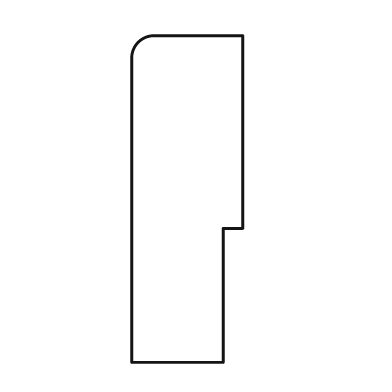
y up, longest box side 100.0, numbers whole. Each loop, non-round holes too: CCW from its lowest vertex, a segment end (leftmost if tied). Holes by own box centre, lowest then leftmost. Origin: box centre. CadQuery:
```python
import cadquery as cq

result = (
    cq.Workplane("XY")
    .moveTo(-17.0, -50.0)
    .lineTo(11.0, -50.0)
    .lineTo(11.0, -9.0)
    .lineTo(17.0, -9.0)
    .lineTo(17.0, 50.0)
    .lineTo(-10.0, 50.0)
    .threePointArc((-15.0, 48.0), (-17.0, 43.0))
    .close()
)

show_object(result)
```